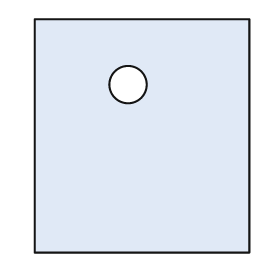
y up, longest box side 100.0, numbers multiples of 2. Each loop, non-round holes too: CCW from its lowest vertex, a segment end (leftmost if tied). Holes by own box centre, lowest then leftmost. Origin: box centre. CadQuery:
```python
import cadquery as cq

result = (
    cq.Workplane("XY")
    .moveTo(-46.0, -50.0)
    .lineTo(46.0, -50.0)
    .lineTo(46.0, 50.0)
    .lineTo(-46.0, 50.0)
    .close()
    .moveTo(-6.0, 22.0)
    .circle(8.0)
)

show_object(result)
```